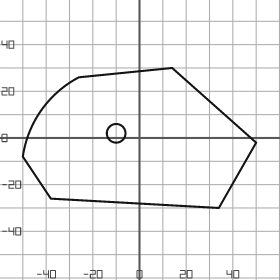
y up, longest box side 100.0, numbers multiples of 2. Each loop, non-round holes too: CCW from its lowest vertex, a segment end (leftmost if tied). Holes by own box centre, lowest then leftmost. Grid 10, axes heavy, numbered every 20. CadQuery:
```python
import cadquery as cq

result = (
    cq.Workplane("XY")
    .moveTo(34.0, -30.0)
    .lineTo(50.0, -2.0)
    .lineTo(14.0, 30.0)
    .lineTo(-26.0, 26.0)
    .threePointArc((-42.0, 12.0), (-50.0, -8.0))
    .lineTo(-38.0, -26.0)
    .close()
    .moveTo(-10.0, 2.0)
    .circle(4.0)
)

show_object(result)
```